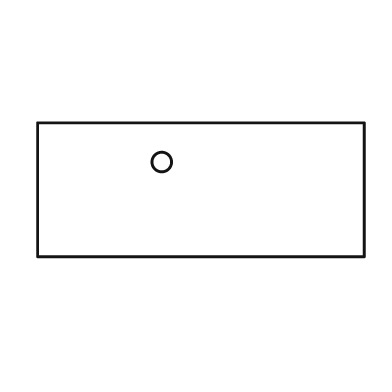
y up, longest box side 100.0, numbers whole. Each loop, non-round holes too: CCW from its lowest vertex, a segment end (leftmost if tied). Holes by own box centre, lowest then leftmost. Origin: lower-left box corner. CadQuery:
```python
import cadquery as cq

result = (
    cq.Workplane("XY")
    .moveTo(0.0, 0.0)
    .lineTo(100.0, 0.0)
    .lineTo(100.0, 41.0)
    .lineTo(0.0, 41.0)
    .close()
    .moveTo(38.0, 29.0)
    .circle(3.0)
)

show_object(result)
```